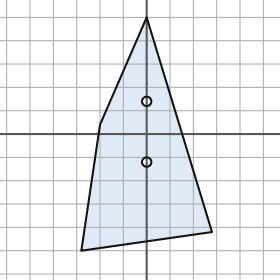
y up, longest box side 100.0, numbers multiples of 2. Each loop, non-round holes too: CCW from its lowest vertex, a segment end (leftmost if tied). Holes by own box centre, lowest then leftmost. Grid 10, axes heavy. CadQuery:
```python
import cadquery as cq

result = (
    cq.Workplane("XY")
    .moveTo(-28.0, -50.0)
    .lineTo(28.0, -42.0)
    .lineTo(0.0, 50.0)
    .lineTo(-20.0, 4.0)
    .close()
    .moveTo(0.0, -12.0)
    .circle(2.0)
    .moveTo(0.0, 14.0)
    .circle(2.0)
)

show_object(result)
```